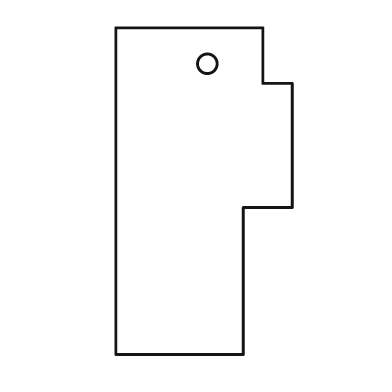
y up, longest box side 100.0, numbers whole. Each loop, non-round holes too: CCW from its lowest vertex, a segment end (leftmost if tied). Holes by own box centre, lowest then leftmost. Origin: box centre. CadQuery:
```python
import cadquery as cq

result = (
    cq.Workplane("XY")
    .moveTo(-27.0, -50.0)
    .lineTo(12.0, -50.0)
    .lineTo(12.0, -5.0)
    .lineTo(27.0, -5.0)
    .lineTo(27.0, 33.0)
    .lineTo(18.0, 33.0)
    .lineTo(18.0, 50.0)
    .lineTo(-27.0, 50.0)
    .close()
    .moveTo(1.0, 39.0)
    .circle(3.0)
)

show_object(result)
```